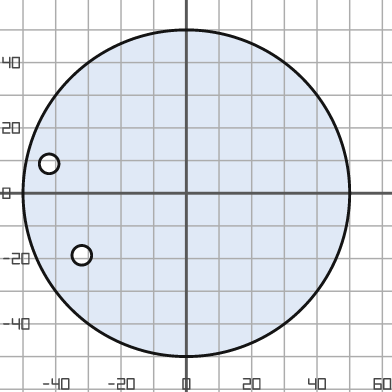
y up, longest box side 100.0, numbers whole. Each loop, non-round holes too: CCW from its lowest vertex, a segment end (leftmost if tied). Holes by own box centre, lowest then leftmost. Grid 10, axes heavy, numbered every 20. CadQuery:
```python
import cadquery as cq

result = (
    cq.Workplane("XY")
    .moveTo(0.0, 0.0)
    .circle(50.0)
    .moveTo(-32.0, -19.0)
    .circle(3.0)
    .moveTo(-42.0, 9.0)
    .circle(3.0)
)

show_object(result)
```